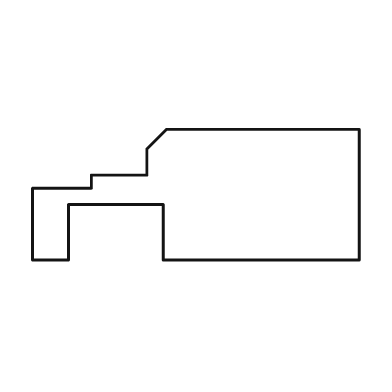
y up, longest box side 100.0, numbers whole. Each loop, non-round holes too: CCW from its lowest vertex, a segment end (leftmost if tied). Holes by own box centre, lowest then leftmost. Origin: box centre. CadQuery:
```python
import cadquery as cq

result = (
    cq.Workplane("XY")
    .moveTo(-50.0, -20.0)
    .lineTo(-39.0, -20.0)
    .lineTo(-39.0, -3.0)
    .lineTo(-10.0, -3.0)
    .lineTo(-10.0, -20.0)
    .lineTo(50.0, -20.0)
    .lineTo(50.0, 20.0)
    .lineTo(-9.0, 20.0)
    .lineTo(-15.0, 14.0)
    .lineTo(-15.0, 6.0)
    .lineTo(-32.0, 6.0)
    .lineTo(-32.0, 2.0)
    .lineTo(-50.0, 2.0)
    .close()
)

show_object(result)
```